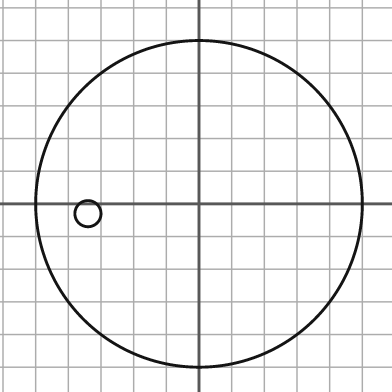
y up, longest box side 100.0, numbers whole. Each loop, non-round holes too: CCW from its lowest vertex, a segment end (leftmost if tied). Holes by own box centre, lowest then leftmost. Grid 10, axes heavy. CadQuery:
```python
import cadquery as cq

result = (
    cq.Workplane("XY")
    .moveTo(0.0, 0.0)
    .circle(50.0)
    .moveTo(-34.0, -3.0)
    .circle(4.0)
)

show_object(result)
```